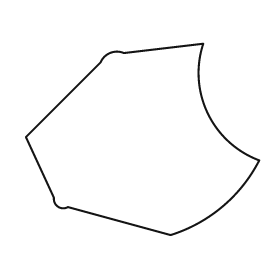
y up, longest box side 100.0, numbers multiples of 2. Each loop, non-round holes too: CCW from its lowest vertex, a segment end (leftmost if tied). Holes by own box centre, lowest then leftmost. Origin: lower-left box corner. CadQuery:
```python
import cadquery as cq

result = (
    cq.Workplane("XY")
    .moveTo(62.0, 0.0)
    .threePointArc((84.0, 12.0), (100.0, 32.0))
    .threePointArc((78.0, 52.0), (76.0, 82.0))
    .lineTo(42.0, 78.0)
    .threePointArc((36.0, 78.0), (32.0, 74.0))
    .lineTo(0.0, 42.0)
    .lineTo(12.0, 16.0)
    .threePointArc((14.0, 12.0), (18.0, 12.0))
    .close()
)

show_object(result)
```